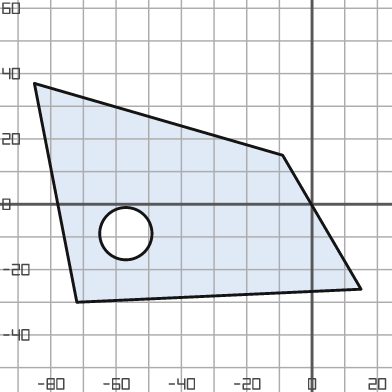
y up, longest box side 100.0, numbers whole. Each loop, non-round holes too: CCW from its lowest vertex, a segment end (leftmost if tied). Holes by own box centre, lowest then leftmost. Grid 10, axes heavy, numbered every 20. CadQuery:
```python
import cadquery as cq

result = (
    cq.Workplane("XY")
    .moveTo(-72.0, -30.0)
    .lineTo(15.0, -26.0)
    .lineTo(-9.0, 15.0)
    .lineTo(-85.0, 37.0)
    .close()
    .moveTo(-57.0, -9.0)
    .circle(8.0)
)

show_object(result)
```